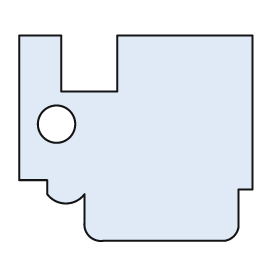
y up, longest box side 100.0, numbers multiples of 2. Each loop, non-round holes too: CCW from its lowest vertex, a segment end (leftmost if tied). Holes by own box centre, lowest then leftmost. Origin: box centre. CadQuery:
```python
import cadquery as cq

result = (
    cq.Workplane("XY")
    .moveTo(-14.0, -44.0)
    .lineTo(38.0, -44.0)
    .threePointArc((42.0, -42.0), (44.0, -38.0))
    .lineTo(44.0, -22.0)
    .lineTo(50.0, -22.0)
    .lineTo(50.0, 44.0)
    .lineTo(-8.0, 44.0)
    .lineTo(-8.0, 20.0)
    .lineTo(-32.0, 20.0)
    .lineTo(-32.0, 44.0)
    .lineTo(-50.0, 44.0)
    .lineTo(-50.0, -18.0)
    .lineTo(-38.0, -18.0)
    .lineTo(-38.0, -24.0)
    .threePointArc((-30.0, -28.0), (-22.0, -24.0))
    .lineTo(-22.0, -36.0)
    .threePointArc((-20.0, -42.0), (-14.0, -44.0))
    .close()
    .moveTo(-34.0, 6.0)
    .circle(8.0)
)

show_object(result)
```